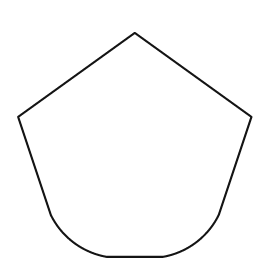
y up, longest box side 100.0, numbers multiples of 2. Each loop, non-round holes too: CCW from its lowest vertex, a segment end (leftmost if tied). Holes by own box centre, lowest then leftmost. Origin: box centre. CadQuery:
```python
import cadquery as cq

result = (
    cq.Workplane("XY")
    .moveTo(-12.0, -48.0)
    .lineTo(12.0, -48.0)
    .threePointArc((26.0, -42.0), (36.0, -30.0))
    .lineTo(50.0, 12.0)
    .lineTo(0.0, 48.0)
    .lineTo(-50.0, 12.0)
    .lineTo(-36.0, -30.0)
    .threePointArc((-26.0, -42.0), (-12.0, -48.0))
    .close()
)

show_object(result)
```